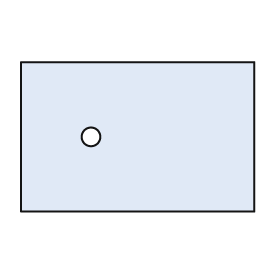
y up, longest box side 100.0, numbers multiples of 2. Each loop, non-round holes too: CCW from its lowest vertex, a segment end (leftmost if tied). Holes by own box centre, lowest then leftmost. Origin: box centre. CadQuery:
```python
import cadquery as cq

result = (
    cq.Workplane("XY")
    .moveTo(-50.0, -32.0)
    .lineTo(50.0, -32.0)
    .lineTo(50.0, 32.0)
    .lineTo(-50.0, 32.0)
    .close()
    .moveTo(-20.0, 0.0)
    .circle(4.0)
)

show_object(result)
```